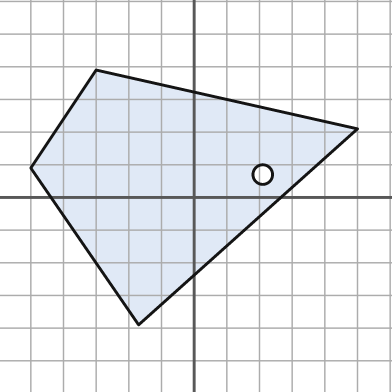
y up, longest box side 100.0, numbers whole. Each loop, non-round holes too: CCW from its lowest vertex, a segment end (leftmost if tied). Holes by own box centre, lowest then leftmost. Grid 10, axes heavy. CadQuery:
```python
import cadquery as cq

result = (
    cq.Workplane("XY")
    .moveTo(-17.0, -39.0)
    .lineTo(50.0, 21.0)
    .lineTo(-30.0, 39.0)
    .lineTo(-50.0, 9.0)
    .close()
    .moveTo(21.0, 7.0)
    .circle(3.0)
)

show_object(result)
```